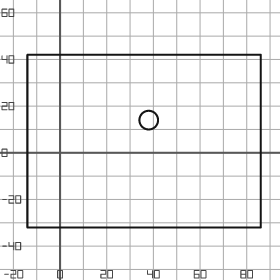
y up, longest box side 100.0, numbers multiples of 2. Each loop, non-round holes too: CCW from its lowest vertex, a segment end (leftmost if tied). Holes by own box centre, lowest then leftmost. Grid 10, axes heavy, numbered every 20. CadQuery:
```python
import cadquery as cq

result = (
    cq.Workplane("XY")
    .moveTo(-14.0, -32.0)
    .lineTo(86.0, -32.0)
    .lineTo(86.0, 42.0)
    .lineTo(-14.0, 42.0)
    .close()
    .moveTo(38.0, 14.0)
    .circle(4.0)
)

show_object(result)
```